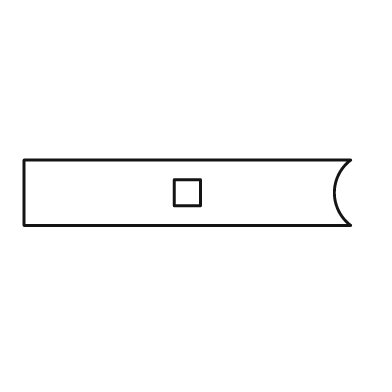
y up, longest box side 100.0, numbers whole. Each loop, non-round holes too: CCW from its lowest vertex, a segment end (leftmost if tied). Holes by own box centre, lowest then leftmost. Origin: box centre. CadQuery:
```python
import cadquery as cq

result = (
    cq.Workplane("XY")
    .moveTo(-50.0, -10.0)
    .lineTo(50.0, -10.0)
    .threePointArc((45.0, 0.0), (50.0, 10.0))
    .lineTo(-50.0, 10.0)
    .close()
    .moveTo(-4.0, -4.0)
    .lineTo(4.0, -4.0)
    .lineTo(4.0, 4.0)
    .lineTo(-4.0, 4.0)
    .close()
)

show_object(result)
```